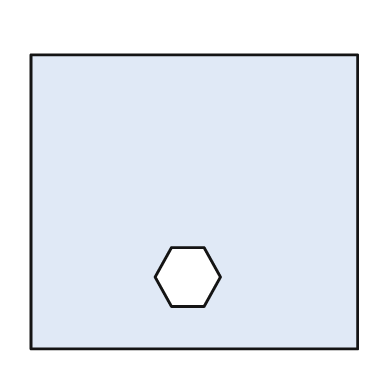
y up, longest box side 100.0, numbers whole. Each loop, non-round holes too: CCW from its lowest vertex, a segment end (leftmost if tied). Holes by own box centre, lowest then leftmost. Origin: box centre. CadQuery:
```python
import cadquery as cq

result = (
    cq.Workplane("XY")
    .moveTo(-50.0, -45.0)
    .lineTo(50.0, -45.0)
    .lineTo(50.0, 45.0)
    .lineTo(-50.0, 45.0)
    .close()
    .moveTo(-7.0, -32.0)
    .lineTo(3.0, -32.0)
    .lineTo(8.0, -23.0)
    .lineTo(3.0, -14.0)
    .lineTo(-7.0, -14.0)
    .lineTo(-12.0, -23.0)
    .close()
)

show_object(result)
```